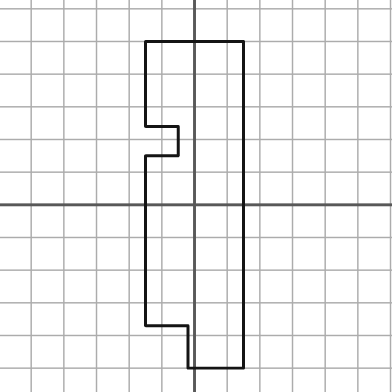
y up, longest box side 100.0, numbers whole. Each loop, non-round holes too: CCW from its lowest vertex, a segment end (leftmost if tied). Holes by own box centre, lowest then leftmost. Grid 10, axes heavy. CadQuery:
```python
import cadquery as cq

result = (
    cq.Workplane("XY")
    .moveTo(-2.0, -50.0)
    .lineTo(15.0, -50.0)
    .lineTo(15.0, 50.0)
    .lineTo(-15.0, 50.0)
    .lineTo(-15.0, 24.0)
    .lineTo(-5.0, 24.0)
    .lineTo(-5.0, 15.0)
    .lineTo(-15.0, 15.0)
    .lineTo(-15.0, -37.0)
    .lineTo(-2.0, -37.0)
    .close()
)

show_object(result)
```